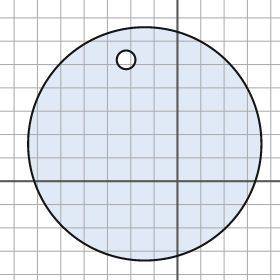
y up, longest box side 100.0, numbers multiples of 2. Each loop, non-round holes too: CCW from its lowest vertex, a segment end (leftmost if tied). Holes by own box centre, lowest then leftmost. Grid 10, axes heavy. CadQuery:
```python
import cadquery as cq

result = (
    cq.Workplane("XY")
    .moveTo(-14.0, 16.0)
    .circle(50.0)
    .moveTo(-22.0, 52.0)
    .circle(4.0)
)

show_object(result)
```